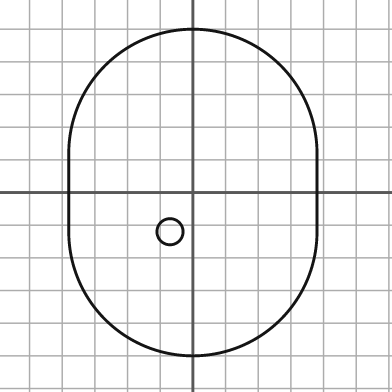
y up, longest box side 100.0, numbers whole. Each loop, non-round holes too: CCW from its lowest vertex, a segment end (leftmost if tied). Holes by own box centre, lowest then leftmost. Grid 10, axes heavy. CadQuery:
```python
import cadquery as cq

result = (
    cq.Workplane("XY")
    .moveTo(-38.0, -12.0)
    .threePointArc((0.0, -50.0), (38.0, -12.0))
    .lineTo(38.0, 12.0)
    .threePointArc((0.0, 50.0), (-38.0, 12.0))
    .close()
    .moveTo(-7.0, -12.0)
    .circle(4.0)
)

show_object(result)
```